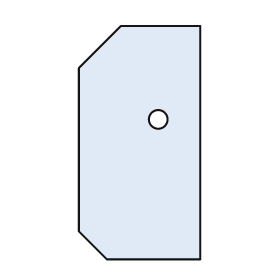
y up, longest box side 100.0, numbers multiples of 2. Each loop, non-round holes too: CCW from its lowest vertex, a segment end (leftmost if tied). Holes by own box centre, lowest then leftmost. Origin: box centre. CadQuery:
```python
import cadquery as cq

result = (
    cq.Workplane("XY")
    .moveTo(-14.0, -50.0)
    .lineTo(26.0, -50.0)
    .lineTo(26.0, 50.0)
    .lineTo(-8.0, 50.0)
    .lineTo(-26.0, 32.0)
    .lineTo(-26.0, -38.0)
    .close()
    .moveTo(8.0, 10.0)
    .circle(4.0)
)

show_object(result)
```